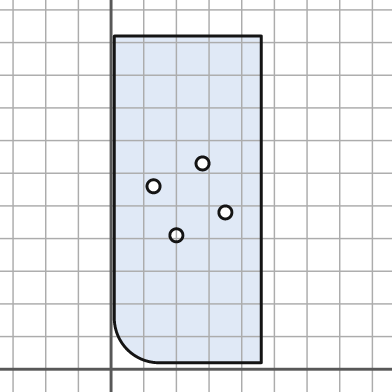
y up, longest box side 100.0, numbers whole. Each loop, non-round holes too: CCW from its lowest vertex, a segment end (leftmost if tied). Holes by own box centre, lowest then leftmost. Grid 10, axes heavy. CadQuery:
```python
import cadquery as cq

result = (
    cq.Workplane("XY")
    .moveTo(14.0, 2.0)
    .lineTo(46.0, 2.0)
    .lineTo(46.0, 102.0)
    .lineTo(1.0, 102.0)
    .lineTo(1.0, 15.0)
    .threePointArc((5.0, 6.0), (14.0, 2.0))
    .close()
    .moveTo(20.0, 41.0)
    .circle(2.0)
    .moveTo(35.0, 48.0)
    .circle(2.0)
    .moveTo(13.0, 56.0)
    .circle(2.0)
    .moveTo(28.0, 63.0)
    .circle(2.0)
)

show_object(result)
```